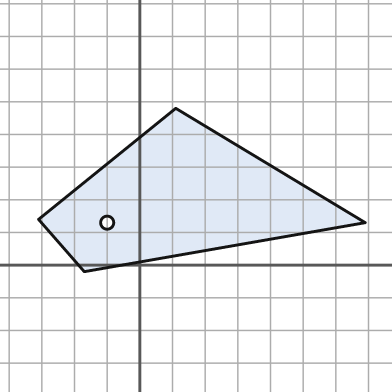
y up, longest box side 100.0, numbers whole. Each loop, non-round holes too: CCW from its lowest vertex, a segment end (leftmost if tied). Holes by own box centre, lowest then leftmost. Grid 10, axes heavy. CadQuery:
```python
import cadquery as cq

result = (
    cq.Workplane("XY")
    .moveTo(-17.0, -2.0)
    .lineTo(69.0, 13.0)
    .lineTo(11.0, 48.0)
    .lineTo(-31.0, 14.0)
    .close()
    .moveTo(-10.0, 13.0)
    .circle(2.0)
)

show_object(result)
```